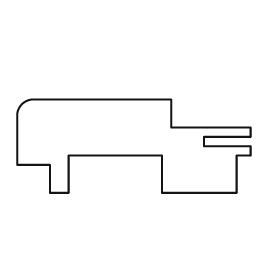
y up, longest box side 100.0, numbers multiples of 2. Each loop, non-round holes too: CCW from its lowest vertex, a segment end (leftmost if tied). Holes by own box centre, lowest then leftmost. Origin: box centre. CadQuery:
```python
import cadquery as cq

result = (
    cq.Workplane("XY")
    .moveTo(-36.0, -20.0)
    .lineTo(-28.0, -20.0)
    .lineTo(-28.0, -4.0)
    .lineTo(12.0, -4.0)
    .lineTo(12.0, -20.0)
    .lineTo(44.0, -20.0)
    .lineTo(44.0, -4.0)
    .lineTo(50.0, -4.0)
    .lineTo(50.0, 0.0)
    .lineTo(30.0, 0.0)
    .lineTo(30.0, 4.0)
    .lineTo(50.0, 4.0)
    .lineTo(50.0, 8.0)
    .lineTo(16.0, 8.0)
    .lineTo(16.0, 20.0)
    .lineTo(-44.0, 20.0)
    .threePointArc((-48.0, 18.0), (-50.0, 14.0))
    .lineTo(-50.0, -8.0)
    .lineTo(-36.0, -8.0)
    .close()
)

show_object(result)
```